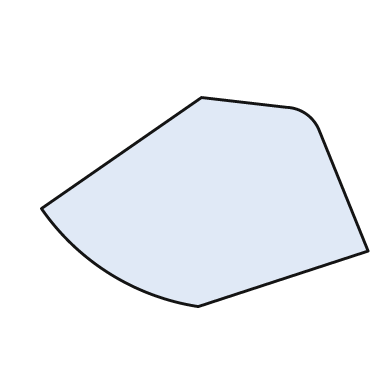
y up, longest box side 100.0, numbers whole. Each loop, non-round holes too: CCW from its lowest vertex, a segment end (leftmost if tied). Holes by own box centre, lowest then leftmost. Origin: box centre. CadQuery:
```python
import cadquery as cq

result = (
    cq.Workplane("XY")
    .moveTo(-2.0, -32.0)
    .lineTo(50.0, -15.0)
    .lineTo(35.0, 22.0)
    .threePointArc((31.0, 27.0), (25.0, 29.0))
    .lineTo(-1.0, 32.0)
    .lineTo(-50.0, -2.0)
    .threePointArc((-29.0, -22.0), (-2.0, -32.0))
    .close()
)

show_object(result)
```